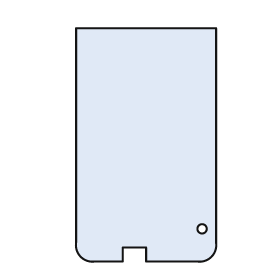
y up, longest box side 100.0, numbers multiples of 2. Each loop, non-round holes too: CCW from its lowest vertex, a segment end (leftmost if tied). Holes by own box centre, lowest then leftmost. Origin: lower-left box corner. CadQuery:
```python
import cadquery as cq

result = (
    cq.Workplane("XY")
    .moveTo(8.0, 0.0)
    .lineTo(20.0, 0.0)
    .lineTo(20.0, 6.0)
    .lineTo(30.0, 6.0)
    .lineTo(30.0, 0.0)
    .lineTo(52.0, 0.0)
    .threePointArc((58.0, 2.0), (60.0, 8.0))
    .lineTo(60.0, 100.0)
    .lineTo(0.0, 100.0)
    .lineTo(0.0, 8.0)
    .threePointArc((2.0, 2.0), (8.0, 0.0))
    .close()
    .moveTo(54.0, 14.0)
    .circle(2.0)
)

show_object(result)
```